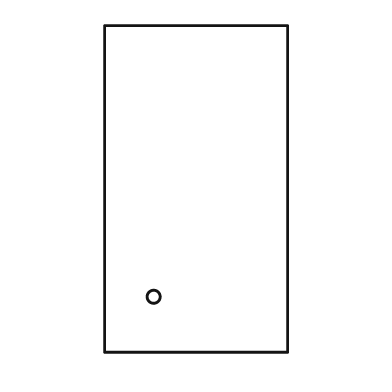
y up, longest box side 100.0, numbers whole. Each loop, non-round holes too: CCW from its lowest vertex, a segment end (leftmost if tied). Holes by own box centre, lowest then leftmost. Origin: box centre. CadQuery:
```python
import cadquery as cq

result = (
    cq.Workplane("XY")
    .moveTo(-28.0, -50.0)
    .lineTo(28.0, -50.0)
    .lineTo(28.0, 50.0)
    .lineTo(-28.0, 50.0)
    .close()
    .moveTo(-13.0, -33.0)
    .circle(2.0)
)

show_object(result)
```